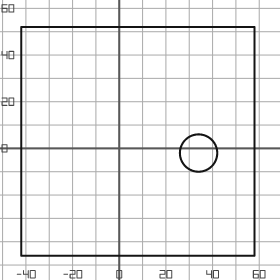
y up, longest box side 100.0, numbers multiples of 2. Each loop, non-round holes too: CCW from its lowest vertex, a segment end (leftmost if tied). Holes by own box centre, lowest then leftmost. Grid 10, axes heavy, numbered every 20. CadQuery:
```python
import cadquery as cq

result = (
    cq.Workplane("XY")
    .moveTo(-42.0, -46.0)
    .lineTo(58.0, -46.0)
    .lineTo(58.0, 52.0)
    .lineTo(-42.0, 52.0)
    .close()
    .moveTo(34.0, -2.0)
    .circle(8.0)
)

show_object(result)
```